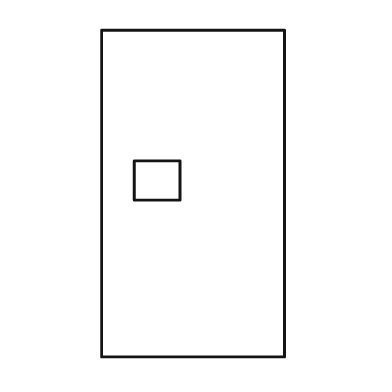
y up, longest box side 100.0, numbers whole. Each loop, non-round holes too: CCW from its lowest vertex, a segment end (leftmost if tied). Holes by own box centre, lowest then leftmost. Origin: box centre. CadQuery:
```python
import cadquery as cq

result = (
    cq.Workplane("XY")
    .moveTo(-28.0, -50.0)
    .lineTo(28.0, -50.0)
    .lineTo(28.0, 50.0)
    .lineTo(-28.0, 50.0)
    .close()
    .moveTo(-18.0, -2.0)
    .lineTo(-4.0, -2.0)
    .lineTo(-4.0, 10.0)
    .lineTo(-18.0, 10.0)
    .close()
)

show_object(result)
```